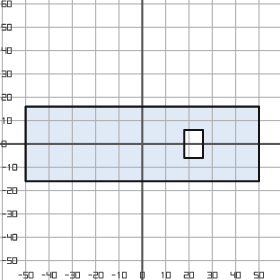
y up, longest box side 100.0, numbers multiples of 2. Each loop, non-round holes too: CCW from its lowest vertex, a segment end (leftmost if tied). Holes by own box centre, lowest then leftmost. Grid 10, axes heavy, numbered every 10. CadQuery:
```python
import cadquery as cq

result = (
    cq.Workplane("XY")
    .moveTo(-50.0, -16.0)
    .lineTo(50.0, -16.0)
    .lineTo(50.0, 16.0)
    .lineTo(-50.0, 16.0)
    .close()
    .moveTo(18.0, -6.0)
    .lineTo(26.0, -6.0)
    .lineTo(26.0, 6.0)
    .lineTo(18.0, 6.0)
    .close()
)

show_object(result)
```